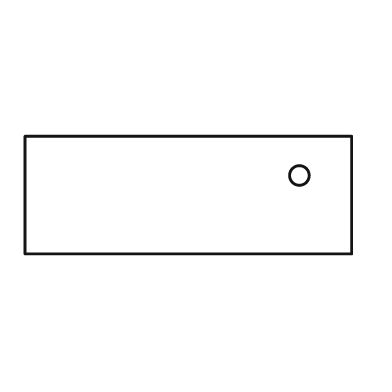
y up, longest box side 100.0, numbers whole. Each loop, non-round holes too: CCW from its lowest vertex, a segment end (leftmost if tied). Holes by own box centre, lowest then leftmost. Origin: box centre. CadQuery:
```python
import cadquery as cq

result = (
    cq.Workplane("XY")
    .moveTo(-50.0, -18.0)
    .lineTo(50.0, -18.0)
    .lineTo(50.0, 18.0)
    .lineTo(-50.0, 18.0)
    .close()
    .moveTo(34.0, 6.0)
    .circle(3.0)
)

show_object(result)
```